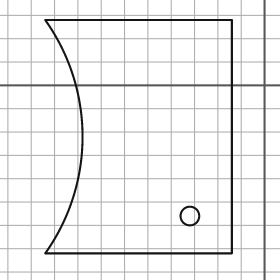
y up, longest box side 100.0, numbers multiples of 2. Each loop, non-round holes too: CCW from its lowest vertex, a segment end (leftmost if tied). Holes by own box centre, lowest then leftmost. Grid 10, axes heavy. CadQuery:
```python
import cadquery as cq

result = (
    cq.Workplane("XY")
    .moveTo(-94.0, -72.0)
    .lineTo(-14.0, -72.0)
    .lineTo(-14.0, 28.0)
    .lineTo(-94.0, 28.0)
    .threePointArc((-78.0, -22.0), (-94.0, -72.0))
    .close()
    .moveTo(-32.0, -56.0)
    .circle(4.0)
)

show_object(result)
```